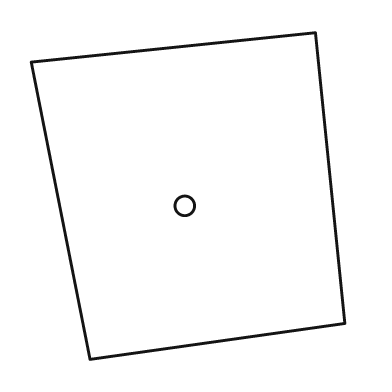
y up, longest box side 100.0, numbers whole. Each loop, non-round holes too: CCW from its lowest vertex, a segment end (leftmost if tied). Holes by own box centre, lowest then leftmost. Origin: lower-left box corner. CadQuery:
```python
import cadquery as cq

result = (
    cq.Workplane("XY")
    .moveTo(18.0, 0.0)
    .lineTo(96.0, 11.0)
    .lineTo(87.0, 100.0)
    .lineTo(0.0, 91.0)
    .close()
    .moveTo(47.0, 47.0)
    .circle(3.0)
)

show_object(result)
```